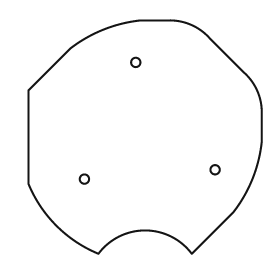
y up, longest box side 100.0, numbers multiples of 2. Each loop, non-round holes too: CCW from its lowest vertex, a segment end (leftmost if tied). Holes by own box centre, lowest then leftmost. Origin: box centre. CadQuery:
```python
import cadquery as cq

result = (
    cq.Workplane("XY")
    .moveTo(-20.0, -50.0)
    .threePointArc((0.0, -40.0), (20.0, -50.0))
    .lineTo(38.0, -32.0)
    .threePointArc((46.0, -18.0), (50.0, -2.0))
    .lineTo(50.0, 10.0)
    .threePointArc((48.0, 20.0), (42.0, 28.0))
    .lineTo(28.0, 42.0)
    .threePointArc((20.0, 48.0), (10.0, 50.0))
    .lineTo(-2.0, 50.0)
    .threePointArc((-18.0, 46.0), (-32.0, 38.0))
    .lineTo(-50.0, 20.0)
    .lineTo(-50.0, -20.0)
    .threePointArc((-38.0, -38.0), (-20.0, -50.0))
    .close()
    .moveTo(-26.0, -18.0)
    .circle(2.0)
    .moveTo(30.0, -14.0)
    .circle(2.0)
    .moveTo(-4.0, 32.0)
    .circle(2.0)
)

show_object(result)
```